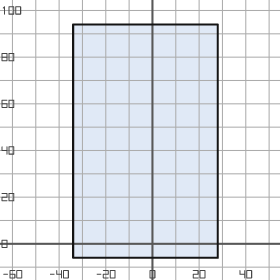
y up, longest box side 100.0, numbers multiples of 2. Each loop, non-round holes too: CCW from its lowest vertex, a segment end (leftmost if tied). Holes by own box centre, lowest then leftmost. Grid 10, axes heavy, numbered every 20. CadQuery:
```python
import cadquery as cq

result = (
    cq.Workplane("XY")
    .moveTo(-34.0, -6.0)
    .lineTo(28.0, -6.0)
    .lineTo(28.0, 94.0)
    .lineTo(-34.0, 94.0)
    .close()
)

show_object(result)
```